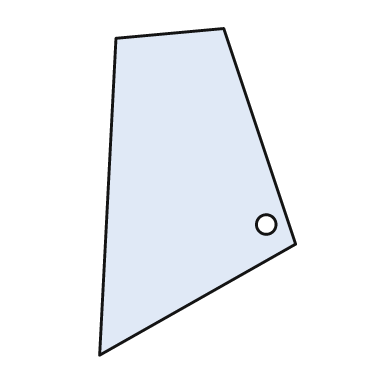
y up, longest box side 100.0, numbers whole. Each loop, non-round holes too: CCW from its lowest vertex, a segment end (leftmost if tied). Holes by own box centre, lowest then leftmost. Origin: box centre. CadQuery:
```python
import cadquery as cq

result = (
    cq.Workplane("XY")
    .moveTo(-30.0, -50.0)
    .lineTo(30.0, -16.0)
    .lineTo(8.0, 50.0)
    .lineTo(-25.0, 47.0)
    .close()
    .moveTo(21.0, -10.0)
    .circle(3.0)
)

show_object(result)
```